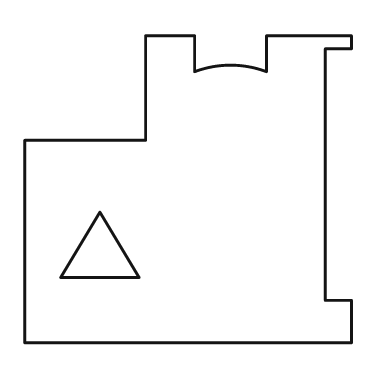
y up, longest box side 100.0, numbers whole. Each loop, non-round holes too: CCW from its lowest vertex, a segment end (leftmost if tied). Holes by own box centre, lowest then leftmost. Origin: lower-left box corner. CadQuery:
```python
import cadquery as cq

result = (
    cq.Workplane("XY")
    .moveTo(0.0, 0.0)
    .lineTo(100.0, 0.0)
    .lineTo(100.0, 13.0)
    .lineTo(92.0, 13.0)
    .lineTo(92.0, 90.0)
    .lineTo(100.0, 90.0)
    .lineTo(100.0, 94.0)
    .lineTo(74.0, 94.0)
    .lineTo(74.0, 83.0)
    .threePointArc((63.0, 85.0), (52.0, 83.0))
    .lineTo(52.0, 94.0)
    .lineTo(37.0, 94.0)
    .lineTo(37.0, 62.0)
    .lineTo(0.0, 62.0)
    .close()
    .moveTo(11.0, 20.0)
    .lineTo(35.0, 20.0)
    .lineTo(23.0, 40.0)
    .close()
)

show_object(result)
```